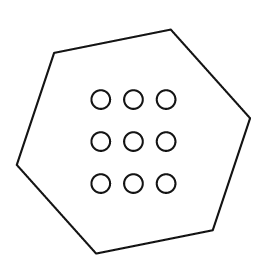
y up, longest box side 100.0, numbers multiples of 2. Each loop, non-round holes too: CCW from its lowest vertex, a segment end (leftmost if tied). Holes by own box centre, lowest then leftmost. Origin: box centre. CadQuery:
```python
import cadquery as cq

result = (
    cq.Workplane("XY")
    .moveTo(-16.0, -48.0)
    .lineTo(34.0, -38.0)
    .lineTo(50.0, 10.0)
    .lineTo(16.0, 48.0)
    .lineTo(-34.0, 38.0)
    .lineTo(-50.0, -10.0)
    .close()
    .moveTo(-14.0, -18.0)
    .circle(4.0)
    .moveTo(0.0, -18.0)
    .circle(4.0)
    .moveTo(14.0, -18.0)
    .circle(4.0)
    .moveTo(-14.0, 0.0)
    .circle(4.0)
    .moveTo(0.0, 0.0)
    .circle(4.0)
    .moveTo(14.0, 0.0)
    .circle(4.0)
    .moveTo(-14.0, 18.0)
    .circle(4.0)
    .moveTo(0.0, 18.0)
    .circle(4.0)
    .moveTo(14.0, 18.0)
    .circle(4.0)
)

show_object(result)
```